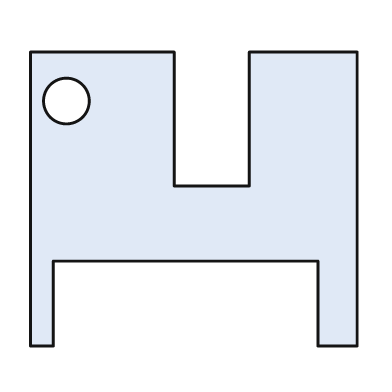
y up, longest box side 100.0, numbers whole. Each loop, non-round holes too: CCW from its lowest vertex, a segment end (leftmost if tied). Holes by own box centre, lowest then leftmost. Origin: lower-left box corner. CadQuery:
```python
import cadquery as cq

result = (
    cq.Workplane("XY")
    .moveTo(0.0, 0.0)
    .lineTo(7.0, 0.0)
    .lineTo(7.0, 26.0)
    .lineTo(88.0, 26.0)
    .lineTo(88.0, 0.0)
    .lineTo(100.0, 0.0)
    .lineTo(100.0, 90.0)
    .lineTo(67.0, 90.0)
    .lineTo(67.0, 49.0)
    .lineTo(44.0, 49.0)
    .lineTo(44.0, 90.0)
    .lineTo(0.0, 90.0)
    .close()
    .moveTo(11.0, 75.0)
    .circle(7.0)
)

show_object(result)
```